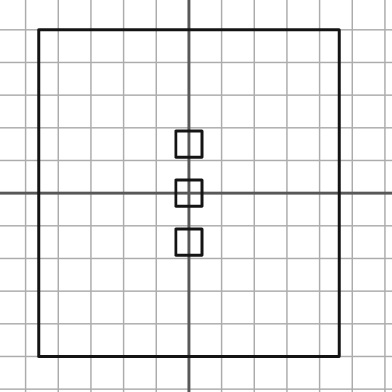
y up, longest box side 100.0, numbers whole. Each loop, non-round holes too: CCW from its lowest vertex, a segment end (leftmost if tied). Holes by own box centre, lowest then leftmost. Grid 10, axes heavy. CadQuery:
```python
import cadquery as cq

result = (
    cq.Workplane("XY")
    .moveTo(-46.0, -50.0)
    .lineTo(46.0, -50.0)
    .lineTo(46.0, 50.0)
    .lineTo(-46.0, 50.0)
    .close()
    .moveTo(-4.0, -19.0)
    .lineTo(4.0, -19.0)
    .lineTo(4.0, -11.0)
    .lineTo(-4.0, -11.0)
    .close()
    .moveTo(-4.0, -4.0)
    .lineTo(4.0, -4.0)
    .lineTo(4.0, 4.0)
    .lineTo(-4.0, 4.0)
    .close()
    .moveTo(-4.0, 11.0)
    .lineTo(4.0, 11.0)
    .lineTo(4.0, 19.0)
    .lineTo(-4.0, 19.0)
    .close()
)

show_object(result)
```